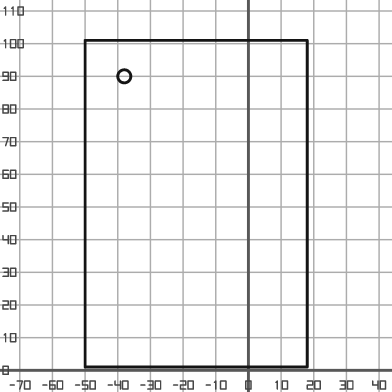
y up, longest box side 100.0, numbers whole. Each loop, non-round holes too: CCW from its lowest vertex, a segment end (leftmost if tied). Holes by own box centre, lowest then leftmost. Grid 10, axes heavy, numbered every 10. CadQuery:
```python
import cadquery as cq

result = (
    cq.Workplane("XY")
    .moveTo(-50.0, 1.0)
    .lineTo(18.0, 1.0)
    .lineTo(18.0, 101.0)
    .lineTo(-50.0, 101.0)
    .close()
    .moveTo(-38.0, 90.0)
    .circle(2.0)
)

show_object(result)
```